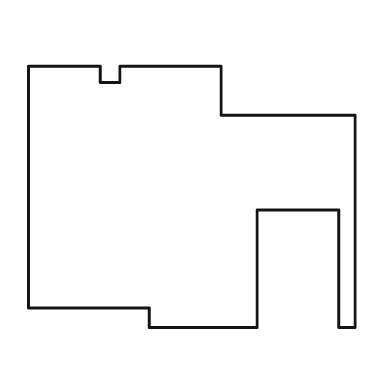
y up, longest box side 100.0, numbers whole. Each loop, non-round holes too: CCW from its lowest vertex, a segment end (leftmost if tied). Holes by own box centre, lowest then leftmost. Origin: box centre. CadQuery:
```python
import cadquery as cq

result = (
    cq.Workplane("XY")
    .moveTo(-13.0, -40.0)
    .lineTo(20.0, -40.0)
    .lineTo(20.0, -4.0)
    .lineTo(45.0, -4.0)
    .lineTo(45.0, -40.0)
    .lineTo(50.0, -40.0)
    .lineTo(50.0, 25.0)
    .lineTo(9.0, 25.0)
    .lineTo(9.0, 40.0)
    .lineTo(-22.0, 40.0)
    .lineTo(-22.0, 35.0)
    .lineTo(-28.0, 35.0)
    .lineTo(-28.0, 40.0)
    .lineTo(-50.0, 40.0)
    .lineTo(-50.0, -34.0)
    .lineTo(-13.0, -34.0)
    .close()
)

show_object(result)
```